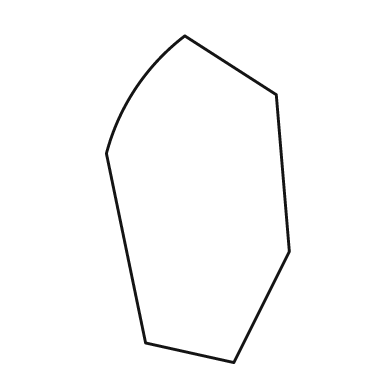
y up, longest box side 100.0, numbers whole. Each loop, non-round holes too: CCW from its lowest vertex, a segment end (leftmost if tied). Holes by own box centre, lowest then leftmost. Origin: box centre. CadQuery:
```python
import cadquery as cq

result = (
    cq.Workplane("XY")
    .moveTo(11.0, -50.0)
    .lineTo(28.0, -16.0)
    .lineTo(24.0, 32.0)
    .lineTo(-4.0, 50.0)
    .threePointArc((-19.0, 34.0), (-28.0, 14.0))
    .lineTo(-16.0, -44.0)
    .close()
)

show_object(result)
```